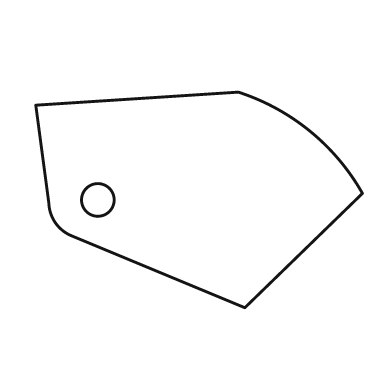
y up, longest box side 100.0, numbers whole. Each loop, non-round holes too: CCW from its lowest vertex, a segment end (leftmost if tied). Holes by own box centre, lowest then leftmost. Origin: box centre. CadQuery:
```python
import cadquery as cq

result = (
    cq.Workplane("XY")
    .moveTo(14.0, -33.0)
    .lineTo(50.0, 2.0)
    .threePointArc((34.0, 21.0), (12.0, 33.0))
    .lineTo(-50.0, 29.0)
    .lineTo(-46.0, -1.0)
    .threePointArc((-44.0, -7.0), (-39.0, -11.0))
    .close()
    .moveTo(-31.0, 0.0)
    .circle(5.0)
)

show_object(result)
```